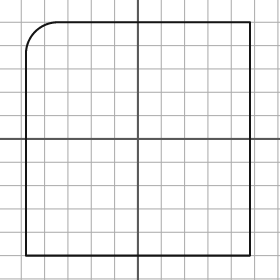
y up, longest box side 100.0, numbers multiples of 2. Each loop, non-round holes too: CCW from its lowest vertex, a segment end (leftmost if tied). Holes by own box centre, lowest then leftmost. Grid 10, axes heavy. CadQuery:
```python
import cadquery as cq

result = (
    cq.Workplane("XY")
    .moveTo(-48.0, -50.0)
    .lineTo(48.0, -50.0)
    .lineTo(48.0, 50.0)
    .lineTo(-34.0, 50.0)
    .threePointArc((-44.0, 46.0), (-48.0, 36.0))
    .close()
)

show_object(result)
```